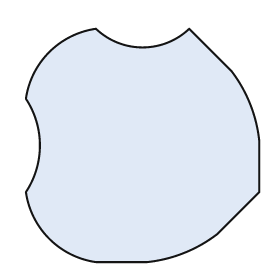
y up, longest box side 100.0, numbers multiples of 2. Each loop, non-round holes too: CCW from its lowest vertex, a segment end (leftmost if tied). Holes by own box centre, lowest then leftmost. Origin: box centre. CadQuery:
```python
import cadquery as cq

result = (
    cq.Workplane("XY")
    .moveTo(-20.0, -50.0)
    .lineTo(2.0, -50.0)
    .threePointArc((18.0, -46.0), (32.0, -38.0))
    .lineTo(50.0, -20.0)
    .lineTo(50.0, 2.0)
    .threePointArc((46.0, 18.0), (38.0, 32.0))
    .lineTo(20.0, 50.0)
    .threePointArc((0.0, 42.0), (-20.0, 50.0))
    .threePointArc((-40.0, 40.0), (-50.0, 20.0))
    .threePointArc((-44.0, 0.0), (-50.0, -20.0))
    .threePointArc((-40.0, -40.0), (-20.0, -50.0))
    .close()
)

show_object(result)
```